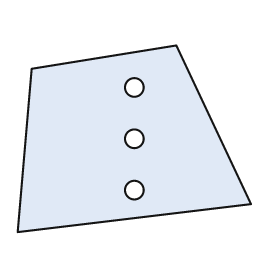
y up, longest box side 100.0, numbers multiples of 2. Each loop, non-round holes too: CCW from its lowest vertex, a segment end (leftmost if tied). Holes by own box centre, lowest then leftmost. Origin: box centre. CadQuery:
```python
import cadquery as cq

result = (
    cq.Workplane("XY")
    .moveTo(-50.0, -40.0)
    .lineTo(50.0, -28.0)
    .lineTo(18.0, 40.0)
    .lineTo(-44.0, 30.0)
    .close()
    .moveTo(0.0, -22.0)
    .circle(4.0)
    .moveTo(0.0, 0.0)
    .circle(4.0)
    .moveTo(0.0, 22.0)
    .circle(4.0)
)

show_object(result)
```